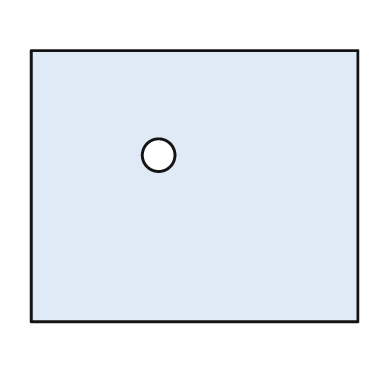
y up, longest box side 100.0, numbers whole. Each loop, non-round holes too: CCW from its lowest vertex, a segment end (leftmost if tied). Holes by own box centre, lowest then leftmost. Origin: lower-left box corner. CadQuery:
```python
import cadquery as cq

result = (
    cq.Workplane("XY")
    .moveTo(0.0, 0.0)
    .lineTo(100.0, 0.0)
    .lineTo(100.0, 83.0)
    .lineTo(0.0, 83.0)
    .close()
    .moveTo(39.0, 51.0)
    .circle(5.0)
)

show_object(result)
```